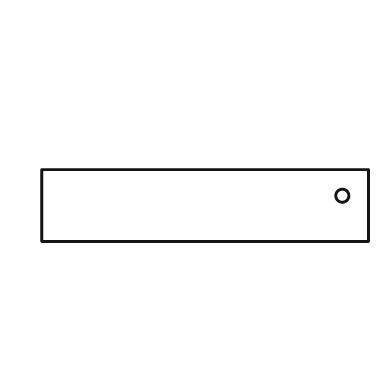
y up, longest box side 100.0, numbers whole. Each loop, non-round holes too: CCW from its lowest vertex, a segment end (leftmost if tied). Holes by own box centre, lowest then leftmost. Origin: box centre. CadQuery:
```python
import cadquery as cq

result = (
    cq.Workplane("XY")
    .moveTo(-50.0, -11.0)
    .lineTo(50.0, -11.0)
    .lineTo(50.0, 11.0)
    .lineTo(-50.0, 11.0)
    .close()
    .moveTo(42.0, 3.0)
    .circle(2.0)
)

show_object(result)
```